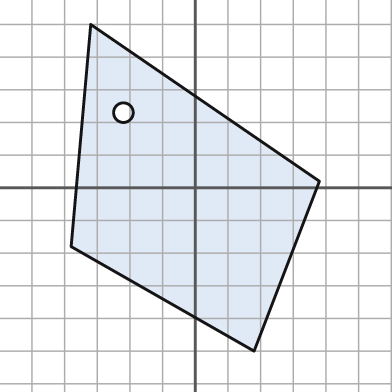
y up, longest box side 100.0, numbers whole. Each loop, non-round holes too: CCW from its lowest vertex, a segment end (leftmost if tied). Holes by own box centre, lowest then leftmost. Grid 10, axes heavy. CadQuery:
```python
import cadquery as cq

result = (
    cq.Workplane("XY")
    .moveTo(18.0, -50.0)
    .lineTo(38.0, 2.0)
    .lineTo(-32.0, 50.0)
    .lineTo(-38.0, -18.0)
    .close()
    .moveTo(-22.0, 23.0)
    .circle(3.0)
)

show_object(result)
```